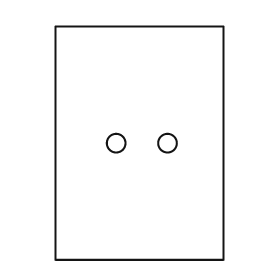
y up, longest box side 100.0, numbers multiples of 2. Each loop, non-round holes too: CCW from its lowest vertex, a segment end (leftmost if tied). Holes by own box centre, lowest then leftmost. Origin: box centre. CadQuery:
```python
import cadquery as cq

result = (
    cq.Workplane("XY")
    .moveTo(-36.0, -50.0)
    .lineTo(36.0, -50.0)
    .lineTo(36.0, 50.0)
    .lineTo(-36.0, 50.0)
    .close()
    .moveTo(-10.0, 0.0)
    .circle(4.0)
    .moveTo(12.0, 0.0)
    .circle(4.0)
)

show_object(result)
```